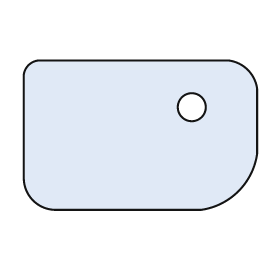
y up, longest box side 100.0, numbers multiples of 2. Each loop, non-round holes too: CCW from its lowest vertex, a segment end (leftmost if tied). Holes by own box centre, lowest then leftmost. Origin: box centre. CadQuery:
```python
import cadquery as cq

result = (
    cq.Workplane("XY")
    .moveTo(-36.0, -32.0)
    .lineTo(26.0, -32.0)
    .threePointArc((42.0, -24.0), (50.0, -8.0))
    .lineTo(50.0, 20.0)
    .threePointArc((46.0, 28.0), (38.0, 32.0))
    .lineTo(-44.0, 32.0)
    .threePointArc((-48.0, 30.0), (-50.0, 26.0))
    .lineTo(-50.0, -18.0)
    .threePointArc((-46.0, -28.0), (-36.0, -32.0))
    .close()
    .moveTo(22.0, 12.0)
    .circle(6.0)
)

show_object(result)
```